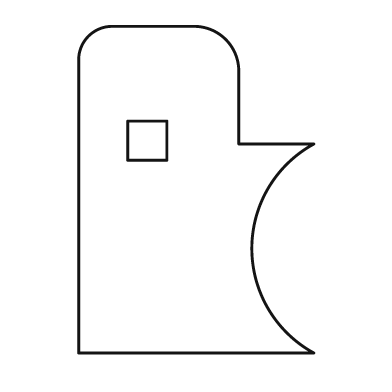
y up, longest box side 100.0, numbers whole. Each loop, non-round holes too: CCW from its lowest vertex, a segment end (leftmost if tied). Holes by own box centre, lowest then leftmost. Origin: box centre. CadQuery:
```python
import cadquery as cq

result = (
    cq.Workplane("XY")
    .moveTo(-36.0, -50.0)
    .lineTo(36.0, -50.0)
    .threePointArc((17.0, -18.0), (36.0, 14.0))
    .lineTo(13.0, 14.0)
    .lineTo(13.0, 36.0)
    .threePointArc((9.0, 46.0), (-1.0, 50.0))
    .lineTo(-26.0, 50.0)
    .threePointArc((-33.0, 47.0), (-36.0, 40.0))
    .close()
    .moveTo(-21.0, 9.0)
    .lineTo(-9.0, 9.0)
    .lineTo(-9.0, 21.0)
    .lineTo(-21.0, 21.0)
    .close()
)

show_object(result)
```